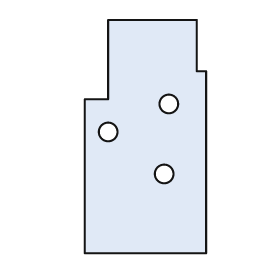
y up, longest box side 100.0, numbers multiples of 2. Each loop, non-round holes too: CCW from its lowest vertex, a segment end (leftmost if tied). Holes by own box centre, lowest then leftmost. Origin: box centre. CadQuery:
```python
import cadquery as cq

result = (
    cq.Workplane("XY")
    .moveTo(-26.0, -50.0)
    .lineTo(26.0, -50.0)
    .lineTo(26.0, 28.0)
    .lineTo(22.0, 28.0)
    .lineTo(22.0, 50.0)
    .lineTo(-16.0, 50.0)
    .lineTo(-16.0, 16.0)
    .lineTo(-26.0, 16.0)
    .close()
    .moveTo(8.0, -16.0)
    .circle(4.0)
    .moveTo(-16.0, 2.0)
    .circle(4.0)
    .moveTo(10.0, 14.0)
    .circle(4.0)
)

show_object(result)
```